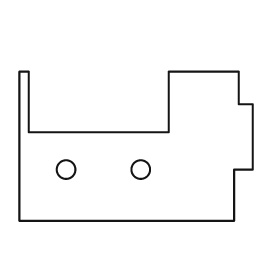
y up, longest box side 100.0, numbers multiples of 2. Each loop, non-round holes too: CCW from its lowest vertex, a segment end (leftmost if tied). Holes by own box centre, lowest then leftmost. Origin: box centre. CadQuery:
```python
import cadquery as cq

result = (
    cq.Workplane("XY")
    .moveTo(-50.0, -32.0)
    .lineTo(42.0, -32.0)
    .lineTo(42.0, -10.0)
    .lineTo(50.0, -10.0)
    .lineTo(50.0, 18.0)
    .lineTo(44.0, 18.0)
    .lineTo(44.0, 32.0)
    .lineTo(14.0, 32.0)
    .lineTo(14.0, 6.0)
    .lineTo(-46.0, 6.0)
    .lineTo(-46.0, 32.0)
    .lineTo(-50.0, 32.0)
    .close()
    .moveTo(-30.0, -10.0)
    .circle(4.0)
    .moveTo(2.0, -10.0)
    .circle(4.0)
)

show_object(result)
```